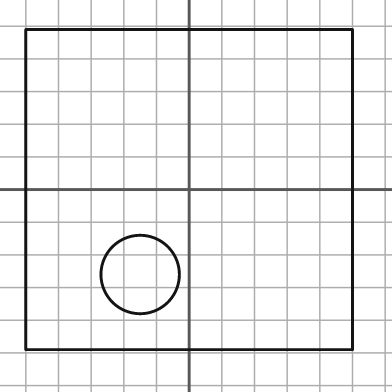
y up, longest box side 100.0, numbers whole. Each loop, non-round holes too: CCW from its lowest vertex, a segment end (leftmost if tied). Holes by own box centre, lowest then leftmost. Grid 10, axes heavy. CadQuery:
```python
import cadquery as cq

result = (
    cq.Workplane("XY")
    .moveTo(-50.0, -49.0)
    .lineTo(50.0, -49.0)
    .lineTo(50.0, 49.0)
    .lineTo(-50.0, 49.0)
    .close()
    .moveTo(-15.0, -26.0)
    .circle(12.0)
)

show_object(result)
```